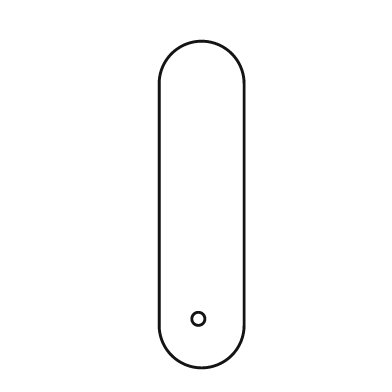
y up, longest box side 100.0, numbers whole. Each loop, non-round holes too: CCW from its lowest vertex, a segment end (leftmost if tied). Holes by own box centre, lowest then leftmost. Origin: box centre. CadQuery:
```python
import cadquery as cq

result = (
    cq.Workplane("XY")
    .moveTo(-13.0, -37.0)
    .threePointArc((0.0, -50.0), (13.0, -37.0))
    .lineTo(13.0, 37.0)
    .threePointArc((0.0, 50.0), (-13.0, 37.0))
    .close()
    .moveTo(-1.0, -35.0)
    .circle(2.0)
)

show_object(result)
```